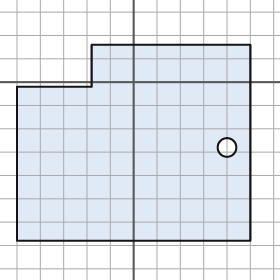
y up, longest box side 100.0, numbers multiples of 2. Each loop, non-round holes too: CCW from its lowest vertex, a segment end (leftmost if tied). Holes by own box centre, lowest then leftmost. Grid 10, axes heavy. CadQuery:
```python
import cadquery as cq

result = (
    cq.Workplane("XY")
    .moveTo(-50.0, -68.0)
    .lineTo(50.0, -68.0)
    .lineTo(50.0, 16.0)
    .lineTo(-18.0, 16.0)
    .lineTo(-18.0, -2.0)
    .lineTo(-50.0, -2.0)
    .close()
    .moveTo(40.0, -28.0)
    .circle(4.0)
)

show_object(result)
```